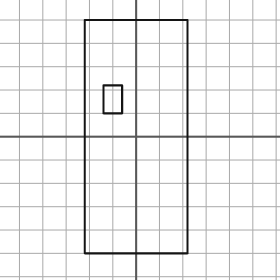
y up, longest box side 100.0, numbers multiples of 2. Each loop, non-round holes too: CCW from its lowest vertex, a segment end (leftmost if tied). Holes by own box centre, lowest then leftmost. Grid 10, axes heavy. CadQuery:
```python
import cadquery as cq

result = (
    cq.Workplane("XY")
    .moveTo(-22.0, -50.0)
    .lineTo(22.0, -50.0)
    .lineTo(22.0, 50.0)
    .lineTo(-22.0, 50.0)
    .close()
    .moveTo(-14.0, 10.0)
    .lineTo(-6.0, 10.0)
    .lineTo(-6.0, 22.0)
    .lineTo(-14.0, 22.0)
    .close()
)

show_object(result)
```